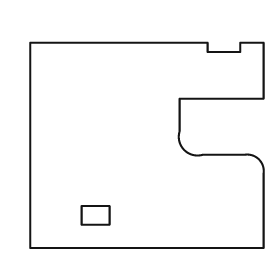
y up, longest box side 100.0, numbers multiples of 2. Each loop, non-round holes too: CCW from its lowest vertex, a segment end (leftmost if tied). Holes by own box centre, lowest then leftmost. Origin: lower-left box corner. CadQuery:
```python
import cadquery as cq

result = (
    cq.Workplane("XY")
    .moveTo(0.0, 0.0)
    .lineTo(100.0, 0.0)
    .lineTo(100.0, 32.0)
    .threePointArc((98.0, 38.0), (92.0, 40.0))
    .lineTo(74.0, 40.0)
    .threePointArc((66.0, 42.0), (64.0, 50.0))
    .lineTo(64.0, 64.0)
    .lineTo(100.0, 64.0)
    .lineTo(100.0, 88.0)
    .lineTo(90.0, 88.0)
    .lineTo(90.0, 84.0)
    .lineTo(76.0, 84.0)
    .lineTo(76.0, 88.0)
    .lineTo(0.0, 88.0)
    .close()
    .moveTo(22.0, 10.0)
    .lineTo(34.0, 10.0)
    .lineTo(34.0, 18.0)
    .lineTo(22.0, 18.0)
    .close()
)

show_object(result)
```